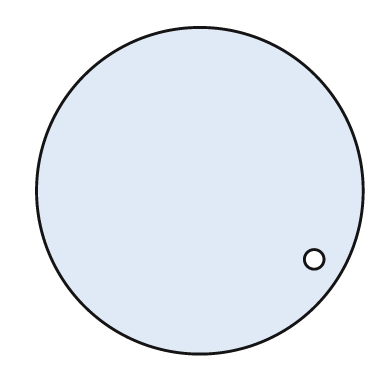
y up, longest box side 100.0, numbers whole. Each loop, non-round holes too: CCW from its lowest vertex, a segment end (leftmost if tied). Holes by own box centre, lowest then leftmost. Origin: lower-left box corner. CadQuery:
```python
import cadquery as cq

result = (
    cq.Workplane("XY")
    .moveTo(50.0, 50.0)
    .circle(50.0)
    .moveTo(85.0, 29.0)
    .circle(3.0)
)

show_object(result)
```